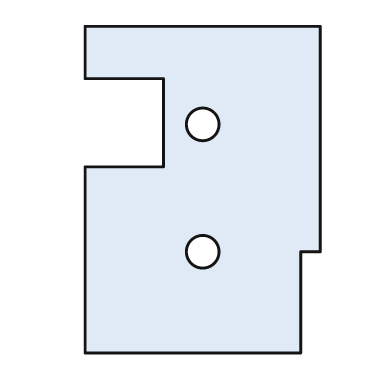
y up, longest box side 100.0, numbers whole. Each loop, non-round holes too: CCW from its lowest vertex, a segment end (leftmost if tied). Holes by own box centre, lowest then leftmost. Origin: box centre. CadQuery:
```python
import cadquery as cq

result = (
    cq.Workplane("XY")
    .moveTo(-36.0, -50.0)
    .lineTo(30.0, -50.0)
    .lineTo(30.0, -19.0)
    .lineTo(36.0, -19.0)
    .lineTo(36.0, 50.0)
    .lineTo(-36.0, 50.0)
    .lineTo(-36.0, 34.0)
    .lineTo(-12.0, 34.0)
    .lineTo(-12.0, 7.0)
    .lineTo(-36.0, 7.0)
    .close()
    .moveTo(0.0, -19.0)
    .circle(5.0)
    .moveTo(0.0, 20.0)
    .circle(5.0)
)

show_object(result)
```